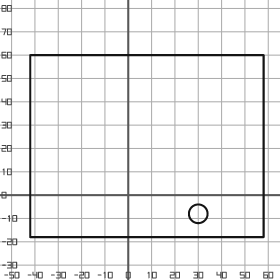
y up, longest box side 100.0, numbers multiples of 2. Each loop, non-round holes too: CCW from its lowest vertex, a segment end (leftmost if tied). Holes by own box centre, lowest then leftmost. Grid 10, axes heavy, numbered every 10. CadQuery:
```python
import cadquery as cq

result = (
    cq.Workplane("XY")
    .moveTo(-42.0, -18.0)
    .lineTo(58.0, -18.0)
    .lineTo(58.0, 60.0)
    .lineTo(-42.0, 60.0)
    .close()
    .moveTo(30.0, -8.0)
    .circle(4.0)
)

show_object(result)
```